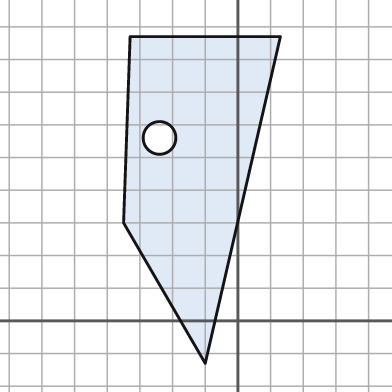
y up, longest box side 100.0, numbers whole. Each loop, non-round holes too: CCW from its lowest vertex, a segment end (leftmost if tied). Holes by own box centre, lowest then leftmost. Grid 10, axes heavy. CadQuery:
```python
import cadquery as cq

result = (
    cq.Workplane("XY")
    .moveTo(-10.0, -13.0)
    .lineTo(13.0, 87.0)
    .lineTo(-33.0, 87.0)
    .lineTo(-35.0, 30.0)
    .close()
    .moveTo(-24.0, 56.0)
    .circle(5.0)
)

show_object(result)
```